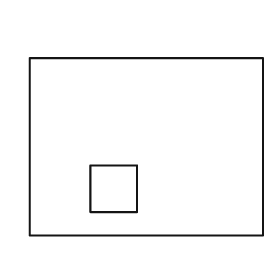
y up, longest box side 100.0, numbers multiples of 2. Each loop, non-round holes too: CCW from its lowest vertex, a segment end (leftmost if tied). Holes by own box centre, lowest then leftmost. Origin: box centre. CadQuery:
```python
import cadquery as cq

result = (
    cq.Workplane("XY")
    .moveTo(-50.0, -38.0)
    .lineTo(50.0, -38.0)
    .lineTo(50.0, 38.0)
    .lineTo(-50.0, 38.0)
    .close()
    .moveTo(-24.0, -28.0)
    .lineTo(-4.0, -28.0)
    .lineTo(-4.0, -8.0)
    .lineTo(-24.0, -8.0)
    .close()
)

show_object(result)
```